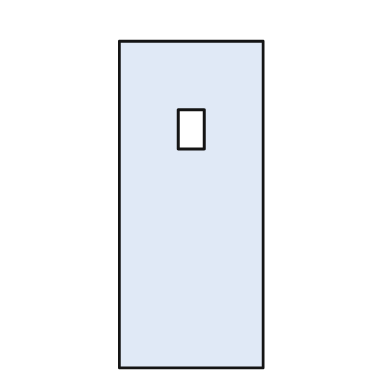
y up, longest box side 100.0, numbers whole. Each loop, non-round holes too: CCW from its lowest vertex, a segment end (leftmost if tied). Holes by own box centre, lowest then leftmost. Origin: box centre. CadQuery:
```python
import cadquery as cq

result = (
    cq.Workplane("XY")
    .moveTo(-22.0, -50.0)
    .lineTo(22.0, -50.0)
    .lineTo(22.0, 50.0)
    .lineTo(-22.0, 50.0)
    .close()
    .moveTo(-4.0, 17.0)
    .lineTo(4.0, 17.0)
    .lineTo(4.0, 29.0)
    .lineTo(-4.0, 29.0)
    .close()
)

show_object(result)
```